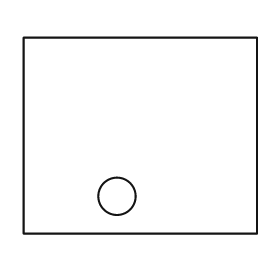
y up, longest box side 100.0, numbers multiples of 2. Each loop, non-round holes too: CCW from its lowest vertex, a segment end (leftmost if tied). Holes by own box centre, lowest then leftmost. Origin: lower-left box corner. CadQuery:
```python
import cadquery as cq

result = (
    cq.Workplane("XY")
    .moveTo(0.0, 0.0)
    .lineTo(100.0, 0.0)
    .lineTo(100.0, 84.0)
    .lineTo(0.0, 84.0)
    .close()
    .moveTo(40.0, 16.0)
    .circle(8.0)
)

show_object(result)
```